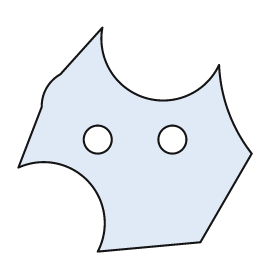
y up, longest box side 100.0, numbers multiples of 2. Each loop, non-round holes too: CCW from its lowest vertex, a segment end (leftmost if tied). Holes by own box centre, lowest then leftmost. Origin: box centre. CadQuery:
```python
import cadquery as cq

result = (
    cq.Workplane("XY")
    .moveTo(-16.0, -48.0)
    .lineTo(28.0, -44.0)
    .lineTo(50.0, -6.0)
    .threePointArc((40.0, 12.0), (36.0, 32.0))
    .threePointArc((4.0, 18.0), (-14.0, 48.0))
    .lineTo(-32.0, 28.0)
    .threePointArc((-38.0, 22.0), (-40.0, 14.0))
    .lineTo(-50.0, -12.0)
    .threePointArc((-20.0, -18.0), (-16.0, -48.0))
    .close()
    .moveTo(-16.0, 0.0)
    .circle(6.0)
    .moveTo(16.0, 0.0)
    .circle(6.0)
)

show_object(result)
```